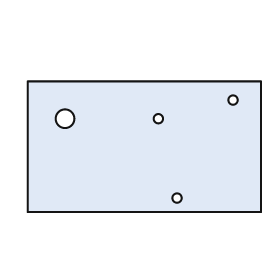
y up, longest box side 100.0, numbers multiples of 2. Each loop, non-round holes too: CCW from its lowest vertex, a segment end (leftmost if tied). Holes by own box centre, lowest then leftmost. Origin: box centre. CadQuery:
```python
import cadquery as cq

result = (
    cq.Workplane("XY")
    .moveTo(-50.0, -28.0)
    .lineTo(50.0, -28.0)
    .lineTo(50.0, 28.0)
    .lineTo(-50.0, 28.0)
    .close()
    .moveTo(14.0, -22.0)
    .circle(2.0)
    .moveTo(-34.0, 12.0)
    .circle(4.0)
    .moveTo(6.0, 12.0)
    .circle(2.0)
    .moveTo(38.0, 20.0)
    .circle(2.0)
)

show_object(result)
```